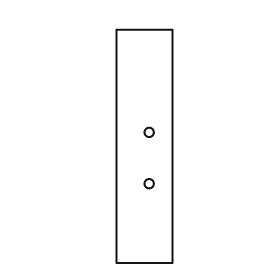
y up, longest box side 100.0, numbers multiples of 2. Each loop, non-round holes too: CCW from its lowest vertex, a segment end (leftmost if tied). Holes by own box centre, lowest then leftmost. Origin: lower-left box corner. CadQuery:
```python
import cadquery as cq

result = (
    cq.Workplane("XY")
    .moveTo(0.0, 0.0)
    .lineTo(24.0, 0.0)
    .lineTo(24.0, 100.0)
    .lineTo(0.0, 100.0)
    .close()
    .moveTo(14.0, 34.0)
    .circle(2.0)
    .moveTo(14.0, 56.0)
    .circle(2.0)
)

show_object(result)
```